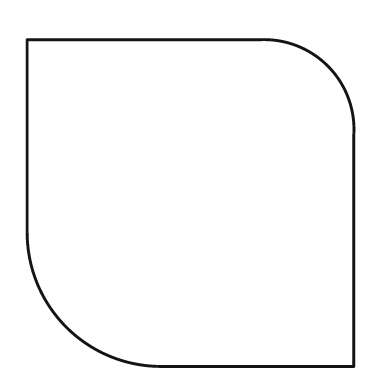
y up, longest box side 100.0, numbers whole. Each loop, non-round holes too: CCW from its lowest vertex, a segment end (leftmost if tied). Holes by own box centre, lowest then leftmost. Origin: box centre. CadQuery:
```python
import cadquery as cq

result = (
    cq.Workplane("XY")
    .moveTo(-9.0, -50.0)
    .lineTo(50.0, -50.0)
    .lineTo(50.0, 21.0)
    .threePointArc((42.0, 42.0), (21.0, 50.0))
    .lineTo(-50.0, 50.0)
    .lineTo(-50.0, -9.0)
    .threePointArc((-38.0, -38.0), (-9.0, -50.0))
    .close()
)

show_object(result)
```